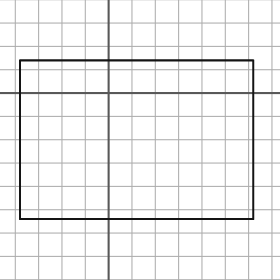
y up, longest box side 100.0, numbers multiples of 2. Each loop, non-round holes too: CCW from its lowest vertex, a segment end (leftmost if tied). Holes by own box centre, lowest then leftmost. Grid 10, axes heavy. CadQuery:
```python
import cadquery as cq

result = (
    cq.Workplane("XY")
    .moveTo(-38.0, -54.0)
    .lineTo(62.0, -54.0)
    .lineTo(62.0, 14.0)
    .lineTo(-38.0, 14.0)
    .close()
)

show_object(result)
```